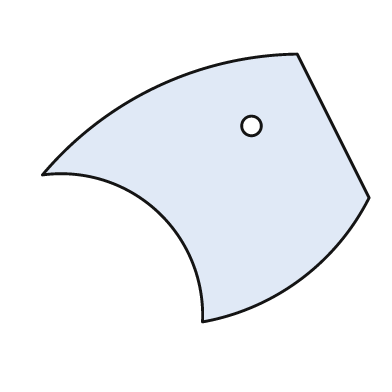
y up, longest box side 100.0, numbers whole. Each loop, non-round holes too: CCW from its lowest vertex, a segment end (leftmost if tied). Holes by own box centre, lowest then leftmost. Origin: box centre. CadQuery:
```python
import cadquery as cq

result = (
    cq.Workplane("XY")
    .moveTo(-1.0, -41.0)
    .threePointArc((29.0, -28.0), (50.0, -3.0))
    .lineTo(28.0, 41.0)
    .threePointArc((-15.0, 31.0), (-50.0, 4.0))
    .threePointArc((-15.0, -7.0), (-1.0, -41.0))
    .close()
    .moveTo(14.0, 19.0)
    .circle(3.0)
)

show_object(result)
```